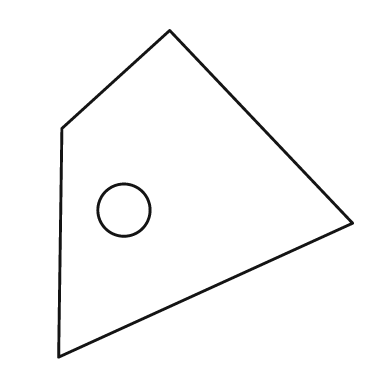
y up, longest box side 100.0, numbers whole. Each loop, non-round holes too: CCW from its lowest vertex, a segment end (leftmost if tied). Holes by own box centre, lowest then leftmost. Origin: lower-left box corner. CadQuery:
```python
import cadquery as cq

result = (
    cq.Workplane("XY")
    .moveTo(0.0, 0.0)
    .lineTo(90.0, 41.0)
    .lineTo(34.0, 100.0)
    .lineTo(1.0, 70.0)
    .close()
    .moveTo(20.0, 45.0)
    .circle(8.0)
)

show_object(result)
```